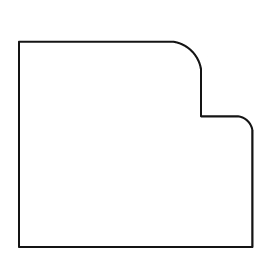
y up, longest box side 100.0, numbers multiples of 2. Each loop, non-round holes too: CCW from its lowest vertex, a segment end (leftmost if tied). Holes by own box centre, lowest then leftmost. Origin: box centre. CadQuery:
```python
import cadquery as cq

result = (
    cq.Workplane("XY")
    .moveTo(-50.0, -44.0)
    .lineTo(50.0, -44.0)
    .lineTo(50.0, 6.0)
    .threePointArc((48.0, 10.0), (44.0, 12.0))
    .lineTo(28.0, 12.0)
    .lineTo(28.0, 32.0)
    .threePointArc((24.0, 40.0), (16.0, 44.0))
    .lineTo(-50.0, 44.0)
    .close()
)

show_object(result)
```